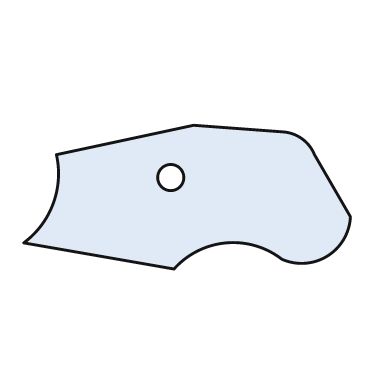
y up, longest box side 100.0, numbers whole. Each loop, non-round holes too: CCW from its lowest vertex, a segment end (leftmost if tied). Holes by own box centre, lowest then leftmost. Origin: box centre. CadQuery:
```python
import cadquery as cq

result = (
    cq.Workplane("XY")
    .moveTo(-4.0, -22.0)
    .threePointArc((12.0, -14.0), (29.0, -19.0))
    .threePointArc((43.0, -18.0), (50.0, -6.0))
    .lineTo(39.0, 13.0)
    .threePointArc((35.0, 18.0), (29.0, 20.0))
    .lineTo(2.0, 22.0)
    .lineTo(-40.0, 13.0)
    .threePointArc((-41.0, -2.0), (-50.0, -14.0))
    .close()
    .moveTo(-5.0, 6.0)
    .circle(4.0)
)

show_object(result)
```